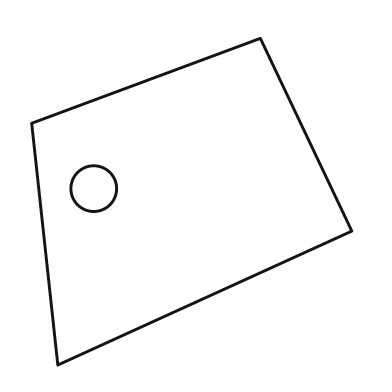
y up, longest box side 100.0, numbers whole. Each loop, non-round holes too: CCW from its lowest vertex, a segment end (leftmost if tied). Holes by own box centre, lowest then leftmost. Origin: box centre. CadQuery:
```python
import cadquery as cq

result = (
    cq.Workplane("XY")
    .moveTo(-41.0, -50.0)
    .lineTo(49.0, -9.0)
    .lineTo(21.0, 50.0)
    .lineTo(-49.0, 24.0)
    .close()
    .moveTo(-30.0, 4.0)
    .circle(7.0)
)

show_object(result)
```